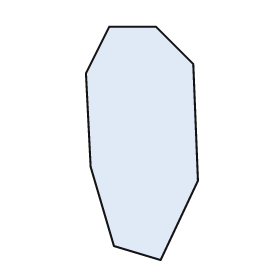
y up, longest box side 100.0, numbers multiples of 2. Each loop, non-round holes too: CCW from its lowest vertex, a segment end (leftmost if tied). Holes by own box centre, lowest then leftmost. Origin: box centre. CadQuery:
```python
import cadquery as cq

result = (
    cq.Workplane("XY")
    .moveTo(8.0, -50.0)
    .lineTo(24.0, -16.0)
    .lineTo(22.0, 34.0)
    .lineTo(6.0, 50.0)
    .lineTo(-14.0, 50.0)
    .lineTo(-24.0, 30.0)
    .lineTo(-22.0, -10.0)
    .lineTo(-12.0, -44.0)
    .close()
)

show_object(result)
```